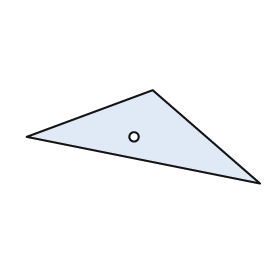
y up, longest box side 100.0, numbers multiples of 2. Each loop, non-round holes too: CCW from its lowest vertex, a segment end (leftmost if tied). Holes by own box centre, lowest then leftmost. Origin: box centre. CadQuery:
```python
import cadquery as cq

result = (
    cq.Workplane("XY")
    .moveTo(50.0, -20.0)
    .lineTo(4.0, 20.0)
    .lineTo(-50.0, 0.0)
    .close()
    .moveTo(-4.0, 0.0)
    .circle(2.0)
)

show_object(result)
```